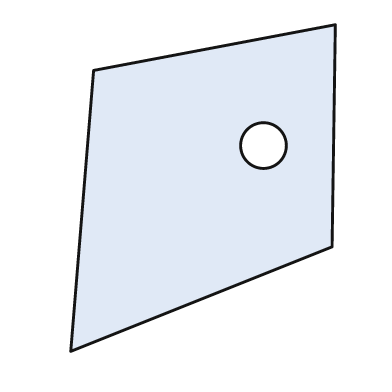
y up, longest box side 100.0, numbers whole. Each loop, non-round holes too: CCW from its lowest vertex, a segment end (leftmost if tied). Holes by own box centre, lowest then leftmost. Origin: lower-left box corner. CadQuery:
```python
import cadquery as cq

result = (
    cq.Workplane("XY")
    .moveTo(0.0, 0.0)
    .lineTo(80.0, 32.0)
    .lineTo(81.0, 100.0)
    .lineTo(7.0, 86.0)
    .close()
    .moveTo(59.0, 63.0)
    .circle(7.0)
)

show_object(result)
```